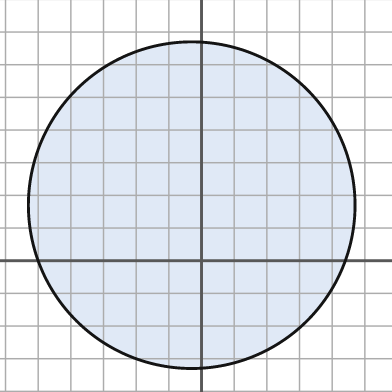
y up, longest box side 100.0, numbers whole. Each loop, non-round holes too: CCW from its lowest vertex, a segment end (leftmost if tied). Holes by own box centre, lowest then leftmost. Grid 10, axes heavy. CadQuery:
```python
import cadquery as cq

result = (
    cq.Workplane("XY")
    .moveTo(-3.0, 17.0)
    .circle(50.0)
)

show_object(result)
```